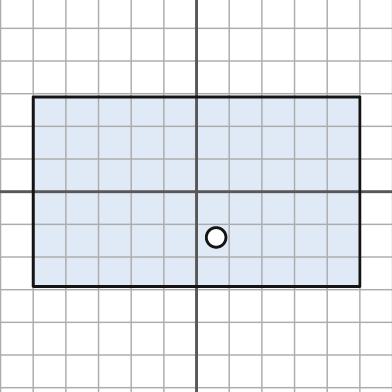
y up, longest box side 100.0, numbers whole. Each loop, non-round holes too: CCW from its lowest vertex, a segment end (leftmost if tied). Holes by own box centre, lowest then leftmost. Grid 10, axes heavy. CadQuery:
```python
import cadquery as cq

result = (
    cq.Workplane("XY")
    .moveTo(-50.0, -29.0)
    .lineTo(50.0, -29.0)
    .lineTo(50.0, 29.0)
    .lineTo(-50.0, 29.0)
    .close()
    .moveTo(6.0, -14.0)
    .circle(3.0)
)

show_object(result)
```